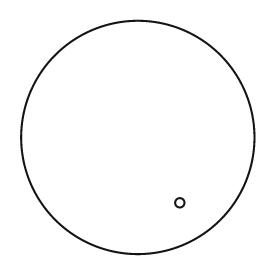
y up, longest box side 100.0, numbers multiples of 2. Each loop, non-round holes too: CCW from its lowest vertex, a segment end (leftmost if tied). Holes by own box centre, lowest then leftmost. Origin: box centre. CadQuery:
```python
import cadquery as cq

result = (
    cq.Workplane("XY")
    .moveTo(0.0, 0.0)
    .circle(50.0)
    .moveTo(18.0, -28.0)
    .circle(2.0)
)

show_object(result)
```